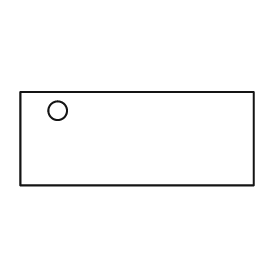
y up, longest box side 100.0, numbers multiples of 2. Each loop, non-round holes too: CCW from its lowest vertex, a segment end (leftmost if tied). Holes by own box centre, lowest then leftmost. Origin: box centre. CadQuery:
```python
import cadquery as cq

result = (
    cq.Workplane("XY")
    .moveTo(-50.0, -20.0)
    .lineTo(50.0, -20.0)
    .lineTo(50.0, 20.0)
    .lineTo(-50.0, 20.0)
    .close()
    .moveTo(-34.0, 12.0)
    .circle(4.0)
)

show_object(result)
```